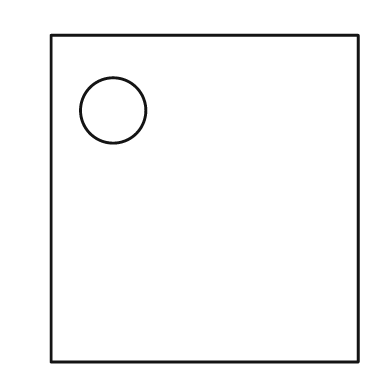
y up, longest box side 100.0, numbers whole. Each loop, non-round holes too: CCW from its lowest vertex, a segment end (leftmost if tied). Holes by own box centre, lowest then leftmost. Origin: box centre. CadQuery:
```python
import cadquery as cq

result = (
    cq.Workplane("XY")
    .moveTo(-47.0, -50.0)
    .lineTo(47.0, -50.0)
    .lineTo(47.0, 50.0)
    .lineTo(-47.0, 50.0)
    .close()
    .moveTo(-28.0, 27.0)
    .circle(10.0)
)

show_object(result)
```